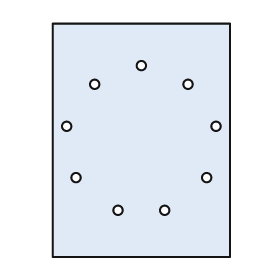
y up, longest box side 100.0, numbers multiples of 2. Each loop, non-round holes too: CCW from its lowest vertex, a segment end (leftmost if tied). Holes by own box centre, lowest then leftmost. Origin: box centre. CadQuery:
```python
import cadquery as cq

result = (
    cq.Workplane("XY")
    .moveTo(-38.0, -50.0)
    .lineTo(38.0, -50.0)
    .lineTo(38.0, 50.0)
    .lineTo(-38.0, 50.0)
    .close()
    .moveTo(-10.0, -30.0)
    .circle(2.0)
    .moveTo(10.0, -30.0)
    .circle(2.0)
    .moveTo(-28.0, -16.0)
    .circle(2.0)
    .moveTo(28.0, -16.0)
    .circle(2.0)
    .moveTo(-32.0, 6.0)
    .circle(2.0)
    .moveTo(32.0, 6.0)
    .circle(2.0)
    .moveTo(-20.0, 24.0)
    .circle(2.0)
    .moveTo(20.0, 24.0)
    .circle(2.0)
    .moveTo(0.0, 32.0)
    .circle(2.0)
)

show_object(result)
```